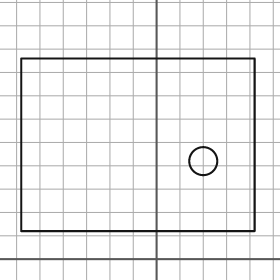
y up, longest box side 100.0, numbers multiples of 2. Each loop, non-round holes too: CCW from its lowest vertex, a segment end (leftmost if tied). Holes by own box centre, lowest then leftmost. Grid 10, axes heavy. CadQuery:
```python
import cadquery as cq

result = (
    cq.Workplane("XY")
    .moveTo(-58.0, 12.0)
    .lineTo(42.0, 12.0)
    .lineTo(42.0, 86.0)
    .lineTo(-58.0, 86.0)
    .close()
    .moveTo(20.0, 42.0)
    .circle(6.0)
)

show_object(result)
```